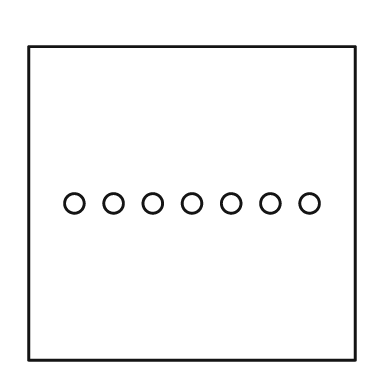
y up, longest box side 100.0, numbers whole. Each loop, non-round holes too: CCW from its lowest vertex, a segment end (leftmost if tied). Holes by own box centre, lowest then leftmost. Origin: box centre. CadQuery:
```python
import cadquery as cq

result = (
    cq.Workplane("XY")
    .moveTo(-50.0, -48.0)
    .lineTo(50.0, -48.0)
    .lineTo(50.0, 48.0)
    .lineTo(-50.0, 48.0)
    .close()
    .moveTo(-36.0, 0.0)
    .circle(3.0)
    .moveTo(-24.0, 0.0)
    .circle(3.0)
    .moveTo(-12.0, 0.0)
    .circle(3.0)
    .moveTo(0.0, 0.0)
    .circle(3.0)
    .moveTo(12.0, 0.0)
    .circle(3.0)
    .moveTo(24.0, 0.0)
    .circle(3.0)
    .moveTo(36.0, 0.0)
    .circle(3.0)
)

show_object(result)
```